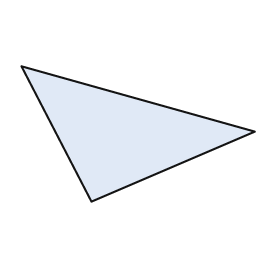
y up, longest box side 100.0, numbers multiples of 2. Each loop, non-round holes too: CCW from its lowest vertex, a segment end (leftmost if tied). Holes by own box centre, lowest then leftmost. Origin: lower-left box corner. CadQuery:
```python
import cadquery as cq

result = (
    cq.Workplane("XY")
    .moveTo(30.0, 0.0)
    .lineTo(100.0, 30.0)
    .lineTo(0.0, 58.0)
    .close()
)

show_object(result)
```